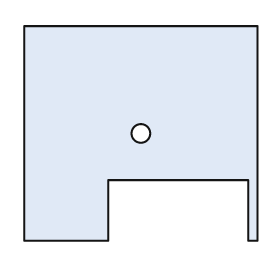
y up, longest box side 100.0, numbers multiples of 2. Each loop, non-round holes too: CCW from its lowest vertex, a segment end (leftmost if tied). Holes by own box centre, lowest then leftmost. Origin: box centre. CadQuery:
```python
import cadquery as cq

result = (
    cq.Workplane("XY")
    .moveTo(-50.0, -46.0)
    .lineTo(-14.0, -46.0)
    .lineTo(-14.0, -20.0)
    .lineTo(46.0, -20.0)
    .lineTo(46.0, -46.0)
    .lineTo(50.0, -46.0)
    .lineTo(50.0, 46.0)
    .lineTo(-50.0, 46.0)
    .close()
    .moveTo(0.0, 0.0)
    .circle(4.0)
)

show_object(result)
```